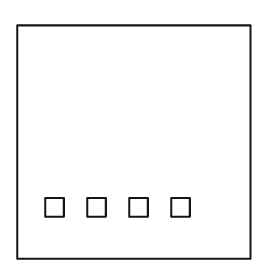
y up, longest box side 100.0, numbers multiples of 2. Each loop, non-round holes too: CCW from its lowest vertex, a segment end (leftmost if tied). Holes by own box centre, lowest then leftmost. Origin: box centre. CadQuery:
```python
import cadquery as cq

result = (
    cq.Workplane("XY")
    .moveTo(-50.0, -50.0)
    .lineTo(50.0, -50.0)
    .lineTo(50.0, 50.0)
    .lineTo(-50.0, 50.0)
    .close()
    .moveTo(-38.0, -32.0)
    .lineTo(-30.0, -32.0)
    .lineTo(-30.0, -24.0)
    .lineTo(-38.0, -24.0)
    .close()
    .moveTo(-20.0, -32.0)
    .lineTo(-12.0, -32.0)
    .lineTo(-12.0, -24.0)
    .lineTo(-20.0, -24.0)
    .close()
    .moveTo(-2.0, -32.0)
    .lineTo(6.0, -32.0)
    .lineTo(6.0, -24.0)
    .lineTo(-2.0, -24.0)
    .close()
    .moveTo(16.0, -32.0)
    .lineTo(24.0, -32.0)
    .lineTo(24.0, -24.0)
    .lineTo(16.0, -24.0)
    .close()
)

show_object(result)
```